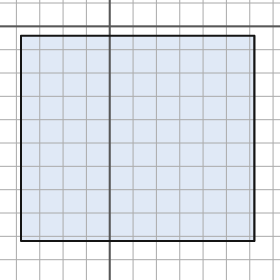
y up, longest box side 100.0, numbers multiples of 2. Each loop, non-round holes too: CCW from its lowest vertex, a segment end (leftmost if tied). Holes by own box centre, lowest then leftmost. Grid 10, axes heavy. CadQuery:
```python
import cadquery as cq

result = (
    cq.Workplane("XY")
    .moveTo(-38.0, -92.0)
    .lineTo(62.0, -92.0)
    .lineTo(62.0, -4.0)
    .lineTo(-38.0, -4.0)
    .close()
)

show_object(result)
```